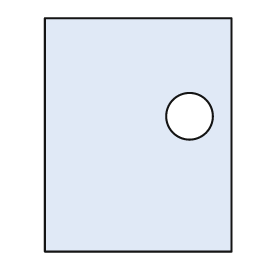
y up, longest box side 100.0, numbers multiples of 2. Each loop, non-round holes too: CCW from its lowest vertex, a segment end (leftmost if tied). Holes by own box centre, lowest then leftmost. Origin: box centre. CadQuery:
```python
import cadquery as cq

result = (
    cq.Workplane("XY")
    .moveTo(-40.0, -50.0)
    .lineTo(40.0, -50.0)
    .lineTo(40.0, 50.0)
    .lineTo(-40.0, 50.0)
    .close()
    .moveTo(22.0, 8.0)
    .circle(10.0)
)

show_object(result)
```